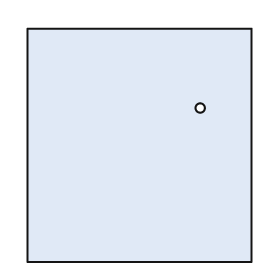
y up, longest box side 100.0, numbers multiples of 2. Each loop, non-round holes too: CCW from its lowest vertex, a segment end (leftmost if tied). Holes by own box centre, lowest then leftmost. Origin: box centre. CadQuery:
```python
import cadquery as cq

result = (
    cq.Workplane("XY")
    .moveTo(-48.0, -50.0)
    .lineTo(48.0, -50.0)
    .lineTo(48.0, 50.0)
    .lineTo(-48.0, 50.0)
    .close()
    .moveTo(26.0, 16.0)
    .circle(2.0)
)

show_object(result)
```